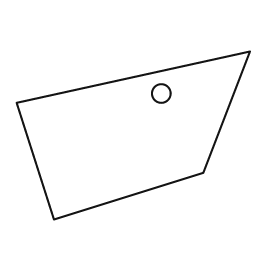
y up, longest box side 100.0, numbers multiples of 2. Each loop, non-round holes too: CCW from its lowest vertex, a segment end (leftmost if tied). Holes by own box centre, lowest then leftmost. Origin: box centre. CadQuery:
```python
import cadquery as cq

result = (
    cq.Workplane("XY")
    .moveTo(-34.0, -36.0)
    .lineTo(30.0, -16.0)
    .lineTo(50.0, 36.0)
    .lineTo(-50.0, 14.0)
    .close()
    .moveTo(12.0, 18.0)
    .circle(4.0)
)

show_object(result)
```